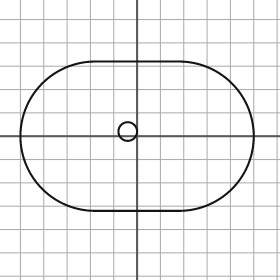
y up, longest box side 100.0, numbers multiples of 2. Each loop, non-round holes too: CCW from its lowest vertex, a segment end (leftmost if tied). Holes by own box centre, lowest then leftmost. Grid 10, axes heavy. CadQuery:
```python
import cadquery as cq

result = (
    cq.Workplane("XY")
    .moveTo(-18.0, -32.0)
    .lineTo(18.0, -32.0)
    .threePointArc((50.0, 0.0), (18.0, 32.0))
    .lineTo(-18.0, 32.0)
    .threePointArc((-50.0, 0.0), (-18.0, -32.0))
    .close()
    .moveTo(-4.0, 2.0)
    .circle(4.0)
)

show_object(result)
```